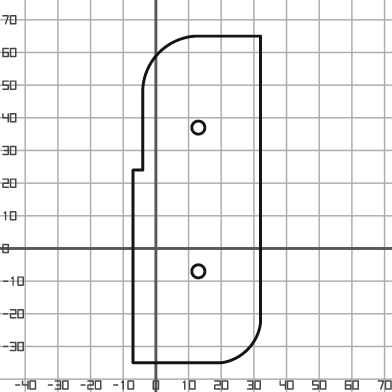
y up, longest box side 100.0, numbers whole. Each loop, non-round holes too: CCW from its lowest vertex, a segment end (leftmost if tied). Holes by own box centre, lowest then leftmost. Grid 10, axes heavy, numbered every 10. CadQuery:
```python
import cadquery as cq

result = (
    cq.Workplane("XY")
    .moveTo(-7.0, -35.0)
    .lineTo(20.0, -35.0)
    .threePointArc((28.0, -31.0), (32.0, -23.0))
    .lineTo(32.0, 65.0)
    .lineTo(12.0, 65.0)
    .threePointArc((1.0, 60.0), (-4.0, 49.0))
    .lineTo(-4.0, 24.0)
    .lineTo(-7.0, 24.0)
    .close()
    .moveTo(13.0, -7.0)
    .circle(2.0)
    .moveTo(13.0, 37.0)
    .circle(2.0)
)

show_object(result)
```